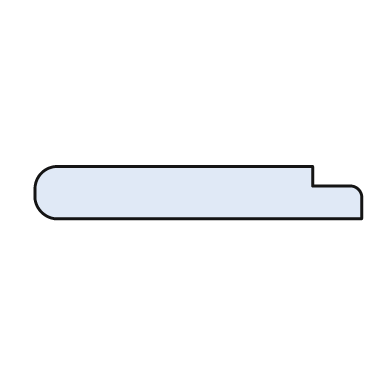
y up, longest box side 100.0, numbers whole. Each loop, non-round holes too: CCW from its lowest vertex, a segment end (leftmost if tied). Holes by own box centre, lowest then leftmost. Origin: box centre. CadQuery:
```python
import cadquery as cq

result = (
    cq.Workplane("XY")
    .moveTo(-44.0, -8.0)
    .lineTo(50.0, -8.0)
    .lineTo(50.0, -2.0)
    .threePointArc((49.0, 1.0), (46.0, 2.0))
    .lineTo(35.0, 2.0)
    .lineTo(35.0, 8.0)
    .lineTo(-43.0, 8.0)
    .threePointArc((-48.0, 6.0), (-50.0, 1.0))
    .lineTo(-50.0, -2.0)
    .threePointArc((-48.0, -6.0), (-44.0, -8.0))
    .close()
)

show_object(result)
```